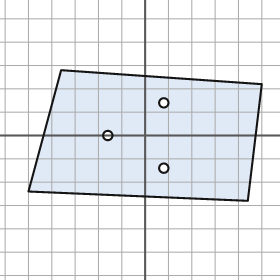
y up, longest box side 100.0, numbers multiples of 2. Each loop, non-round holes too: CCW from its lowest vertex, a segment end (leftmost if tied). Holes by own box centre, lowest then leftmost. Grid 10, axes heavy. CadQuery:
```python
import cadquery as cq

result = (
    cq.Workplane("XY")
    .moveTo(44.0, -28.0)
    .lineTo(50.0, 22.0)
    .lineTo(-36.0, 28.0)
    .lineTo(-50.0, -24.0)
    .close()
    .moveTo(8.0, -14.0)
    .circle(2.0)
    .moveTo(-16.0, 0.0)
    .circle(2.0)
    .moveTo(8.0, 14.0)
    .circle(2.0)
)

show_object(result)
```